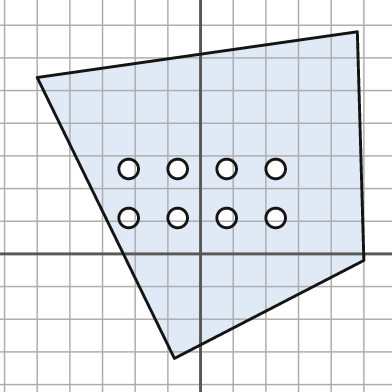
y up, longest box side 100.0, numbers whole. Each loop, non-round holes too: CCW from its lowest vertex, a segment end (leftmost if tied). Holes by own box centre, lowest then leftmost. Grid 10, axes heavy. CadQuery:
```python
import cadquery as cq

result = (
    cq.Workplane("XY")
    .moveTo(-8.0, -32.0)
    .lineTo(50.0, -2.0)
    .lineTo(48.0, 68.0)
    .lineTo(-50.0, 54.0)
    .close()
    .moveTo(-22.0, 11.0)
    .circle(3.0)
    .moveTo(-7.0, 11.0)
    .circle(3.0)
    .moveTo(8.0, 11.0)
    .circle(3.0)
    .moveTo(23.0, 11.0)
    .circle(3.0)
    .moveTo(-22.0, 26.0)
    .circle(3.0)
    .moveTo(-7.0, 26.0)
    .circle(3.0)
    .moveTo(8.0, 26.0)
    .circle(3.0)
    .moveTo(23.0, 26.0)
    .circle(3.0)
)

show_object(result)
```